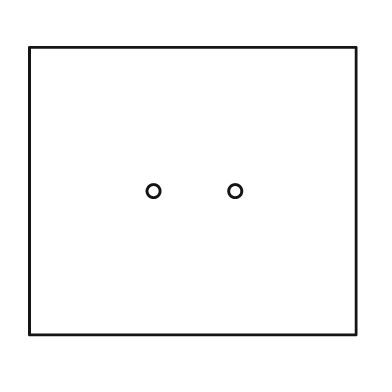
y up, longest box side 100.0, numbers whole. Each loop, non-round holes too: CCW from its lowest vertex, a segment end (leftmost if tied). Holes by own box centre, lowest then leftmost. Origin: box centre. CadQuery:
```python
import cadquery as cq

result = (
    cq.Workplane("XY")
    .moveTo(-50.0, -44.0)
    .lineTo(50.0, -44.0)
    .lineTo(50.0, 44.0)
    .lineTo(-50.0, 44.0)
    .close()
    .moveTo(-12.0, 0.0)
    .circle(2.0)
    .moveTo(13.0, 0.0)
    .circle(2.0)
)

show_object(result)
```